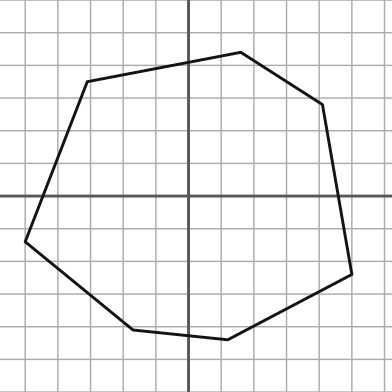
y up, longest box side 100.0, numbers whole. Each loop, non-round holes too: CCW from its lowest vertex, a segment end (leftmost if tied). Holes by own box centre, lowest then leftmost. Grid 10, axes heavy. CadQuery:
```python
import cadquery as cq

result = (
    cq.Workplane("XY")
    .moveTo(12.0, -44.0)
    .lineTo(50.0, -24.0)
    .lineTo(41.0, 28.0)
    .lineTo(16.0, 44.0)
    .lineTo(-31.0, 35.0)
    .lineTo(-50.0, -14.0)
    .lineTo(-17.0, -41.0)
    .close()
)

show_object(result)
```